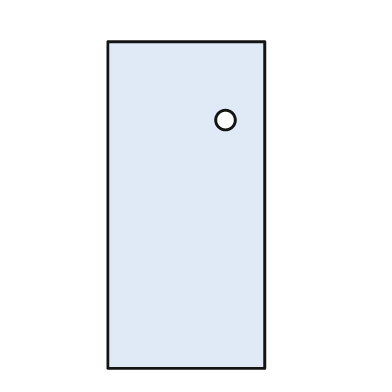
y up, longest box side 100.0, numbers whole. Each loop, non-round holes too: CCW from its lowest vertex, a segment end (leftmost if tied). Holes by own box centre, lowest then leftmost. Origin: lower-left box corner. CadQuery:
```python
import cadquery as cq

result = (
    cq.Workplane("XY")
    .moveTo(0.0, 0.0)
    .lineTo(48.0, 0.0)
    .lineTo(48.0, 100.0)
    .lineTo(0.0, 100.0)
    .close()
    .moveTo(36.0, 76.0)
    .circle(3.0)
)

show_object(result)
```